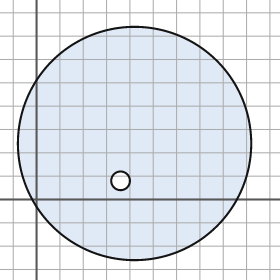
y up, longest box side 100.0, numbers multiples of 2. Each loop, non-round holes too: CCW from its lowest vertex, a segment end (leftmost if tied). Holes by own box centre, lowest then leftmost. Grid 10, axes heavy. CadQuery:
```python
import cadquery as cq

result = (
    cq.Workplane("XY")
    .moveTo(42.0, 24.0)
    .circle(50.0)
    .moveTo(36.0, 8.0)
    .circle(4.0)
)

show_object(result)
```